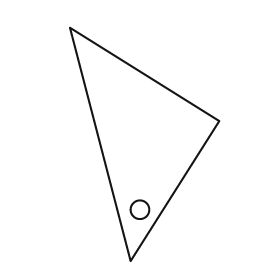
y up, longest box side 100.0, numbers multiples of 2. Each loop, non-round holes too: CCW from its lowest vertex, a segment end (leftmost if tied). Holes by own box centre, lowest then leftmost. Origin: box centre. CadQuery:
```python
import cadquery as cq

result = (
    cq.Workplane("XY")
    .moveTo(-6.0, -50.0)
    .lineTo(32.0, 10.0)
    .lineTo(-32.0, 50.0)
    .close()
    .moveTo(-2.0, -28.0)
    .circle(4.0)
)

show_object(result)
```